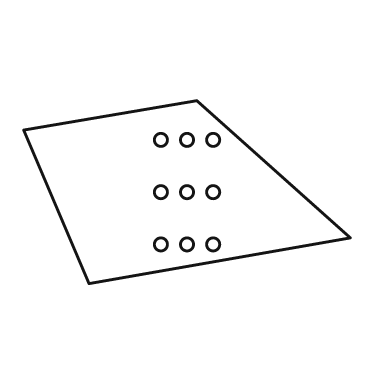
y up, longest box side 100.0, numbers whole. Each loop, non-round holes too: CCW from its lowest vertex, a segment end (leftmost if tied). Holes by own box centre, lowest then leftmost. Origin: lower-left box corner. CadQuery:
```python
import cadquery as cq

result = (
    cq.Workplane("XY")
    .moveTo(20.0, 0.0)
    .lineTo(100.0, 14.0)
    .lineTo(53.0, 56.0)
    .lineTo(0.0, 47.0)
    .close()
    .moveTo(42.0, 12.0)
    .circle(2.0)
    .moveTo(50.0, 12.0)
    .circle(2.0)
    .moveTo(58.0, 12.0)
    .circle(2.0)
    .moveTo(42.0, 28.0)
    .circle(2.0)
    .moveTo(50.0, 28.0)
    .circle(2.0)
    .moveTo(58.0, 28.0)
    .circle(2.0)
    .moveTo(42.0, 44.0)
    .circle(2.0)
    .moveTo(50.0, 44.0)
    .circle(2.0)
    .moveTo(58.0, 44.0)
    .circle(2.0)
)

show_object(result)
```